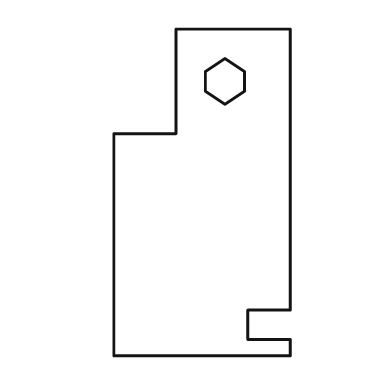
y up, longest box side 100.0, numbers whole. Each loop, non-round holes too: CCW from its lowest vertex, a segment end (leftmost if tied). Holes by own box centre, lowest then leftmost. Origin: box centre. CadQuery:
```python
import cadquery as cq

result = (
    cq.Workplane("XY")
    .moveTo(-27.0, -50.0)
    .lineTo(27.0, -50.0)
    .lineTo(27.0, -45.0)
    .lineTo(14.0, -45.0)
    .lineTo(14.0, -36.0)
    .lineTo(27.0, -36.0)
    .lineTo(27.0, 50.0)
    .lineTo(-8.0, 50.0)
    .lineTo(-8.0, 18.0)
    .lineTo(-27.0, 18.0)
    .close()
    .moveTo(7.0, 27.0)
    .lineTo(13.0, 31.0)
    .lineTo(13.0, 37.0)
    .lineTo(7.0, 41.0)
    .lineTo(1.0, 37.0)
    .lineTo(1.0, 31.0)
    .close()
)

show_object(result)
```